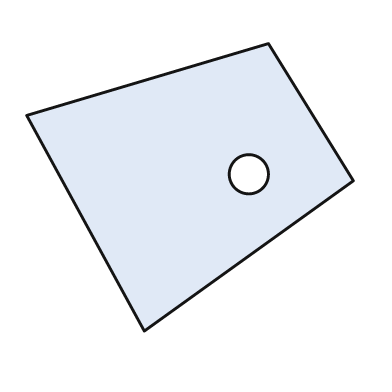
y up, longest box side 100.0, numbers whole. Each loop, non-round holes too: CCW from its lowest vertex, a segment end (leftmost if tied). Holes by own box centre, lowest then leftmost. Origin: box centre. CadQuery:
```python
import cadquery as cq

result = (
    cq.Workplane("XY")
    .moveTo(-14.0, -44.0)
    .lineTo(50.0, 2.0)
    .lineTo(24.0, 44.0)
    .lineTo(-50.0, 22.0)
    .close()
    .moveTo(18.0, 4.0)
    .circle(6.0)
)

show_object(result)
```